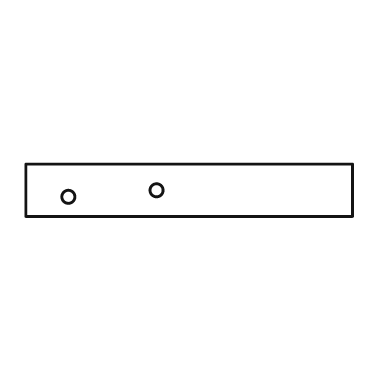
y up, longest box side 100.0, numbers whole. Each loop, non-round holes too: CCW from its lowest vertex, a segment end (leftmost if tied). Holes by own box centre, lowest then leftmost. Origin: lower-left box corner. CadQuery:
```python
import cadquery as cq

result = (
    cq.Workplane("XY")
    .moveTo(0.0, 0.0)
    .lineTo(100.0, 0.0)
    .lineTo(100.0, 16.0)
    .lineTo(0.0, 16.0)
    .close()
    .moveTo(13.0, 6.0)
    .circle(2.0)
    .moveTo(40.0, 8.0)
    .circle(2.0)
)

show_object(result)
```